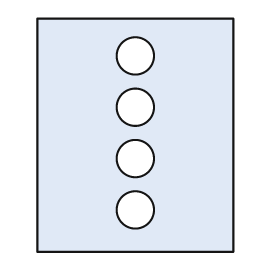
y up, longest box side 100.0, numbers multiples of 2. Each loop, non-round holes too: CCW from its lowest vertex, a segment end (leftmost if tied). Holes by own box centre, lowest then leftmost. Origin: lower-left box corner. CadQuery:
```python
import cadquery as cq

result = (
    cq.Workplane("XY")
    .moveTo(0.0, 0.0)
    .lineTo(84.0, 0.0)
    .lineTo(84.0, 100.0)
    .lineTo(0.0, 100.0)
    .close()
    .moveTo(42.0, 18.0)
    .circle(8.0)
    .moveTo(42.0, 40.0)
    .circle(8.0)
    .moveTo(42.0, 62.0)
    .circle(8.0)
    .moveTo(42.0, 84.0)
    .circle(8.0)
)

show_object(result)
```